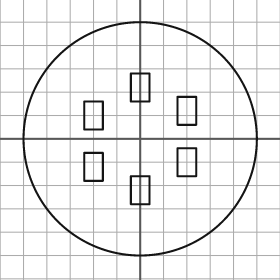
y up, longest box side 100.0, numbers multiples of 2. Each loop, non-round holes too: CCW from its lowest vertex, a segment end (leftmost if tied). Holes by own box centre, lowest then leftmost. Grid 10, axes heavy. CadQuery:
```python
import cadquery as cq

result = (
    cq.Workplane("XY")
    .moveTo(0.0, 0.0)
    .circle(50.0)
    .moveTo(-4.0, -28.0)
    .lineTo(4.0, -28.0)
    .lineTo(4.0, -16.0)
    .lineTo(-4.0, -16.0)
    .close()
    .moveTo(-24.0, -18.0)
    .lineTo(-16.0, -18.0)
    .lineTo(-16.0, -6.0)
    .lineTo(-24.0, -6.0)
    .close()
    .moveTo(16.0, -16.0)
    .lineTo(24.0, -16.0)
    .lineTo(24.0, -4.0)
    .lineTo(16.0, -4.0)
    .close()
    .moveTo(-24.0, 4.0)
    .lineTo(-16.0, 4.0)
    .lineTo(-16.0, 16.0)
    .lineTo(-24.0, 16.0)
    .close()
    .moveTo(16.0, 6.0)
    .lineTo(24.0, 6.0)
    .lineTo(24.0, 18.0)
    .lineTo(16.0, 18.0)
    .close()
    .moveTo(-4.0, 16.0)
    .lineTo(4.0, 16.0)
    .lineTo(4.0, 28.0)
    .lineTo(-4.0, 28.0)
    .close()
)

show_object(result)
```